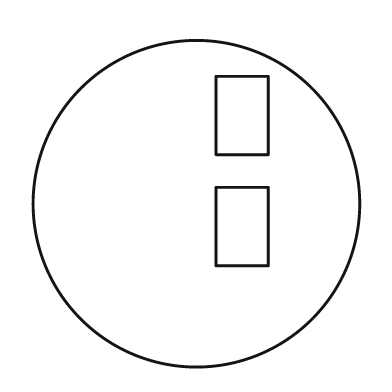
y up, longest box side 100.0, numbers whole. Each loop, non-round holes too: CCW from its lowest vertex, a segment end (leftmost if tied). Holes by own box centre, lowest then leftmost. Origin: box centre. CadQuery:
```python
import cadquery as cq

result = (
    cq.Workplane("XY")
    .moveTo(0.0, 0.0)
    .circle(50.0)
    .moveTo(6.0, -19.0)
    .lineTo(22.0, -19.0)
    .lineTo(22.0, 5.0)
    .lineTo(6.0, 5.0)
    .close()
    .moveTo(6.0, 15.0)
    .lineTo(22.0, 15.0)
    .lineTo(22.0, 39.0)
    .lineTo(6.0, 39.0)
    .close()
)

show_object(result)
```